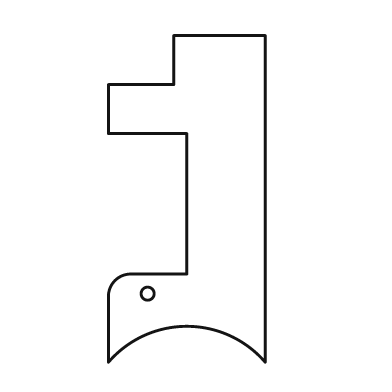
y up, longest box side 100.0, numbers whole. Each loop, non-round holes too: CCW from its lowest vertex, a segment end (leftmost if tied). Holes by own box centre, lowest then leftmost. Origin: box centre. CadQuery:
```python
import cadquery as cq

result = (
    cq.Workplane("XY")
    .moveTo(-24.0, -50.0)
    .threePointArc((0.0, -39.0), (24.0, -50.0))
    .lineTo(24.0, 50.0)
    .lineTo(-4.0, 50.0)
    .lineTo(-4.0, 35.0)
    .lineTo(-24.0, 35.0)
    .lineTo(-24.0, 20.0)
    .lineTo(0.0, 20.0)
    .lineTo(0.0, -23.0)
    .lineTo(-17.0, -23.0)
    .threePointArc((-22.0, -25.0), (-24.0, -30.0))
    .close()
    .moveTo(-12.0, -29.0)
    .circle(2.0)
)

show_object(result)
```